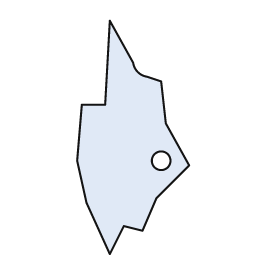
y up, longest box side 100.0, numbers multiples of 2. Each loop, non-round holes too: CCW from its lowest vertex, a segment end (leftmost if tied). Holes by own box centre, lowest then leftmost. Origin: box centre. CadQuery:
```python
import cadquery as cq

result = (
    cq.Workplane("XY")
    .moveTo(-10.0, -50.0)
    .lineTo(-4.0, -38.0)
    .lineTo(4.0, -40.0)
    .lineTo(10.0, -26.0)
    .lineTo(24.0, -12.0)
    .lineTo(14.0, 6.0)
    .lineTo(12.0, 24.0)
    .lineTo(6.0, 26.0)
    .threePointArc((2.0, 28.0), (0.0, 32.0))
    .lineTo(-10.0, 50.0)
    .lineTo(-12.0, 14.0)
    .lineTo(-22.0, 14.0)
    .lineTo(-24.0, -10.0)
    .lineTo(-20.0, -28.0)
    .close()
    .moveTo(12.0, -10.0)
    .circle(4.0)
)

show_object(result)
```